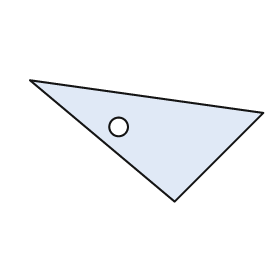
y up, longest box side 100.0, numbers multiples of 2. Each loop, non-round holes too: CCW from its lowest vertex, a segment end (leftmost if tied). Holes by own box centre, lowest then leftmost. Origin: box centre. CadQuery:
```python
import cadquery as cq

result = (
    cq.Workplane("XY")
    .moveTo(12.0, -26.0)
    .lineTo(50.0, 12.0)
    .lineTo(-50.0, 26.0)
    .close()
    .moveTo(-12.0, 6.0)
    .circle(4.0)
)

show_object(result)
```